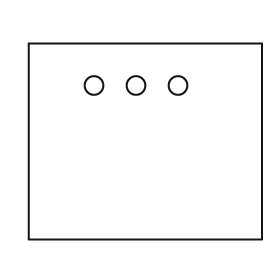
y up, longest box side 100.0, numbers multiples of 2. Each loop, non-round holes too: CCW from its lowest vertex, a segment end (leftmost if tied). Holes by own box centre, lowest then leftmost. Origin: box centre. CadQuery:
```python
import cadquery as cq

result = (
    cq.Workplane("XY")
    .moveTo(-50.0, -42.0)
    .lineTo(50.0, -42.0)
    .lineTo(50.0, 42.0)
    .lineTo(-50.0, 42.0)
    .close()
    .moveTo(-22.0, 24.0)
    .circle(4.0)
    .moveTo(-4.0, 24.0)
    .circle(4.0)
    .moveTo(14.0, 24.0)
    .circle(4.0)
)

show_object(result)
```